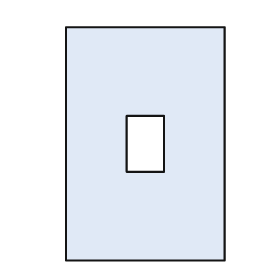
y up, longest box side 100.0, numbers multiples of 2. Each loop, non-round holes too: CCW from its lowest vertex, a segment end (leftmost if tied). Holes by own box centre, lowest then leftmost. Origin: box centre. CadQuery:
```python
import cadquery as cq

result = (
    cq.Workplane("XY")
    .moveTo(-34.0, -50.0)
    .lineTo(34.0, -50.0)
    .lineTo(34.0, 50.0)
    .lineTo(-34.0, 50.0)
    .close()
    .moveTo(-8.0, -12.0)
    .lineTo(8.0, -12.0)
    .lineTo(8.0, 12.0)
    .lineTo(-8.0, 12.0)
    .close()
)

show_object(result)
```